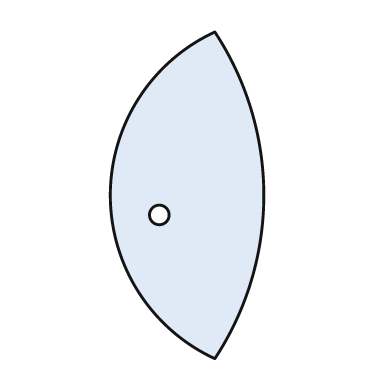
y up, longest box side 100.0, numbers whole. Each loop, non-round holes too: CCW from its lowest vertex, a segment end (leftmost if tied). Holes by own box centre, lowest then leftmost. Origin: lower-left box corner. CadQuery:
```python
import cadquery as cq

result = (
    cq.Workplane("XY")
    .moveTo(32.0, 0.0)
    .threePointArc((47.0, 50.0), (32.0, 100.0))
    .threePointArc((0.0, 50.0), (32.0, 0.0))
    .close()
    .moveTo(15.0, 44.0)
    .circle(3.0)
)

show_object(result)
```